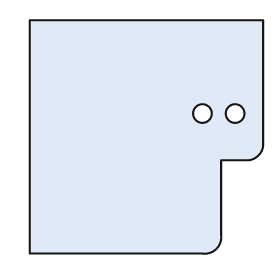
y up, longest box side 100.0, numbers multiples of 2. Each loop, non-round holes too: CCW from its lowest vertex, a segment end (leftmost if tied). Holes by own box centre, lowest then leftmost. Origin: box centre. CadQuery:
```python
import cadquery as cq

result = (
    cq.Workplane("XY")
    .moveTo(-50.0, -50.0)
    .lineTo(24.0, -50.0)
    .threePointArc((30.0, -48.0), (32.0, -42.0))
    .lineTo(32.0, -10.0)
    .lineTo(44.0, -10.0)
    .threePointArc((48.0, -8.0), (50.0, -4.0))
    .lineTo(50.0, 50.0)
    .lineTo(-50.0, 50.0)
    .close()
    .moveTo(24.0, 10.0)
    .circle(4.0)
    .moveTo(38.0, 10.0)
    .circle(4.0)
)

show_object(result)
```